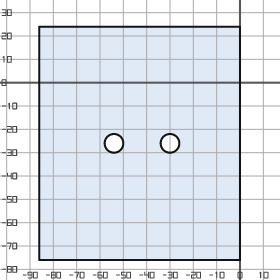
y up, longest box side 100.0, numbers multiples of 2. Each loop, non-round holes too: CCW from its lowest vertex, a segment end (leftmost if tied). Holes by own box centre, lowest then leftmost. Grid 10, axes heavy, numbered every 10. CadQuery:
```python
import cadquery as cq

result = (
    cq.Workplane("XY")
    .moveTo(-86.0, -76.0)
    .lineTo(0.0, -76.0)
    .lineTo(0.0, 24.0)
    .lineTo(-86.0, 24.0)
    .close()
    .moveTo(-54.0, -26.0)
    .circle(4.0)
    .moveTo(-30.0, -26.0)
    .circle(4.0)
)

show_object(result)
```